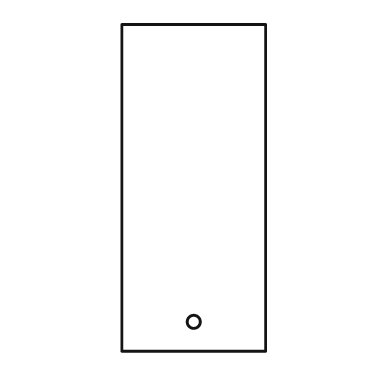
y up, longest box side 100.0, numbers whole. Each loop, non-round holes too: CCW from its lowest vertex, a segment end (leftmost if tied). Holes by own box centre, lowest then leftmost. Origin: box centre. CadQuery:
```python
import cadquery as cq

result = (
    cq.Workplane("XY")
    .moveTo(-22.0, -50.0)
    .lineTo(22.0, -50.0)
    .lineTo(22.0, 50.0)
    .lineTo(-22.0, 50.0)
    .close()
    .moveTo(0.0, -41.0)
    .circle(2.0)
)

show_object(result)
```